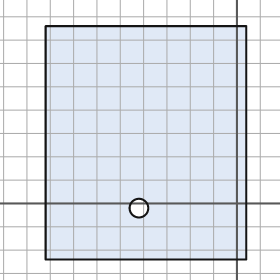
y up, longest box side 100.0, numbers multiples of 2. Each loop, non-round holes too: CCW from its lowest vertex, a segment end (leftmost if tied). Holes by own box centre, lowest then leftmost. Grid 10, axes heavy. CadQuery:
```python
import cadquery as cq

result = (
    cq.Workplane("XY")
    .moveTo(-82.0, -24.0)
    .lineTo(4.0, -24.0)
    .lineTo(4.0, 76.0)
    .lineTo(-82.0, 76.0)
    .close()
    .moveTo(-42.0, -2.0)
    .circle(4.0)
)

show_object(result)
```